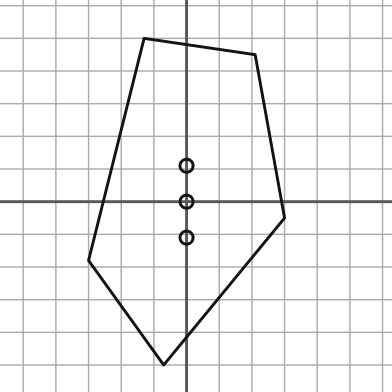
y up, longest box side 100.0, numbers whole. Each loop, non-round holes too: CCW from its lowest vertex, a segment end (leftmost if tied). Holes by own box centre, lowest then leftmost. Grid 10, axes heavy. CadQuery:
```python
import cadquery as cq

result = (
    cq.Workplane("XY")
    .moveTo(-7.0, -50.0)
    .lineTo(30.0, -5.0)
    .lineTo(21.0, 45.0)
    .lineTo(-13.0, 50.0)
    .lineTo(-30.0, -18.0)
    .close()
    .moveTo(0.0, -11.0)
    .circle(2.0)
    .moveTo(0.0, 0.0)
    .circle(2.0)
    .moveTo(0.0, 11.0)
    .circle(2.0)
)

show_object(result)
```